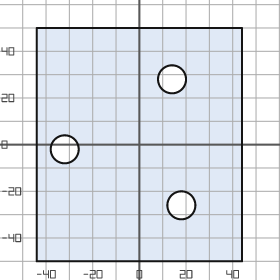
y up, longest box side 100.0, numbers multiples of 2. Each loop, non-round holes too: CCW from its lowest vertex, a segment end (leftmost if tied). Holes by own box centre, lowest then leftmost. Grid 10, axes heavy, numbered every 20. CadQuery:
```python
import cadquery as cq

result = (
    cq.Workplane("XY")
    .moveTo(-44.0, -50.0)
    .lineTo(44.0, -50.0)
    .lineTo(44.0, 50.0)
    .lineTo(-44.0, 50.0)
    .close()
    .moveTo(18.0, -26.0)
    .circle(6.0)
    .moveTo(-32.0, -2.0)
    .circle(6.0)
    .moveTo(14.0, 28.0)
    .circle(6.0)
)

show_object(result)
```